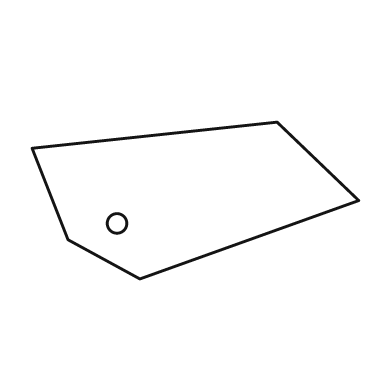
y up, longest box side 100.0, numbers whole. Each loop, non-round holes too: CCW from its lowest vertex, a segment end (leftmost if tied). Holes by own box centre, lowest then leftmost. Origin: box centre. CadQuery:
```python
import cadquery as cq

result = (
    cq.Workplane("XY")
    .moveTo(-17.0, -24.0)
    .lineTo(50.0, 0.0)
    .lineTo(25.0, 24.0)
    .lineTo(-50.0, 16.0)
    .lineTo(-39.0, -12.0)
    .close()
    .moveTo(-24.0, -7.0)
    .circle(3.0)
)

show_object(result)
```